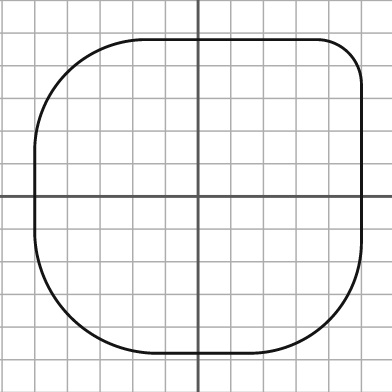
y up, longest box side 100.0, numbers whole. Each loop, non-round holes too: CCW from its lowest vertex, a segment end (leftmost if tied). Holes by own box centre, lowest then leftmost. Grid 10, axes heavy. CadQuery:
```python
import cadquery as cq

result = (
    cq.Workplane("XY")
    .moveTo(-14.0, -48.0)
    .lineTo(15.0, -48.0)
    .threePointArc((40.0, -38.0), (50.0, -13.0))
    .lineTo(50.0, 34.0)
    .threePointArc((46.0, 44.0), (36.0, 48.0))
    .lineTo(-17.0, 48.0)
    .threePointArc((-40.0, 38.0), (-50.0, 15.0))
    .lineTo(-50.0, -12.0)
    .threePointArc((-39.0, -37.0), (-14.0, -48.0))
    .close()
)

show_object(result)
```